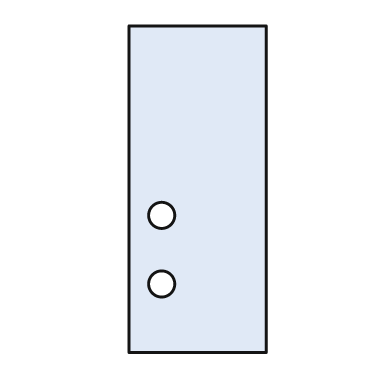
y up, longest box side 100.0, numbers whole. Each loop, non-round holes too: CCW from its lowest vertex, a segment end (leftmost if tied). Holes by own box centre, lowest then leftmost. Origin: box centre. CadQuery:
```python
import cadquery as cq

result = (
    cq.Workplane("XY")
    .moveTo(-21.0, -50.0)
    .lineTo(21.0, -50.0)
    .lineTo(21.0, 50.0)
    .lineTo(-21.0, 50.0)
    .close()
    .moveTo(-11.0, -29.0)
    .circle(4.0)
    .moveTo(-11.0, -8.0)
    .circle(4.0)
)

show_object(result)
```